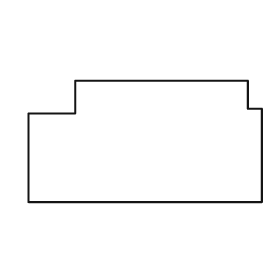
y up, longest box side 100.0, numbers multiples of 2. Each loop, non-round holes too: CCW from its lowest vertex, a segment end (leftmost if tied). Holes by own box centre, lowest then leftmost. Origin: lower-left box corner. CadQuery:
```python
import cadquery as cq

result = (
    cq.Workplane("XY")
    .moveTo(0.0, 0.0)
    .lineTo(100.0, 0.0)
    .lineTo(100.0, 40.0)
    .lineTo(94.0, 40.0)
    .lineTo(94.0, 52.0)
    .lineTo(20.0, 52.0)
    .lineTo(20.0, 38.0)
    .lineTo(0.0, 38.0)
    .close()
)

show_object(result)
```